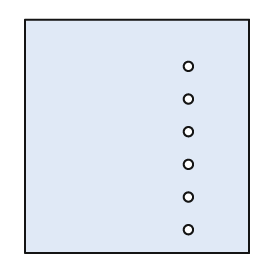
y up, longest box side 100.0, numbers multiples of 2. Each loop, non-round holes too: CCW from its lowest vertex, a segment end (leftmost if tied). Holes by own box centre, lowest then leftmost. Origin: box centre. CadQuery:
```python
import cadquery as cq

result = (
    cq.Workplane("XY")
    .moveTo(-48.0, -50.0)
    .lineTo(48.0, -50.0)
    .lineTo(48.0, 50.0)
    .lineTo(-48.0, 50.0)
    .close()
    .moveTo(22.0, -40.0)
    .circle(2.0)
    .moveTo(22.0, -26.0)
    .circle(2.0)
    .moveTo(22.0, -12.0)
    .circle(2.0)
    .moveTo(22.0, 2.0)
    .circle(2.0)
    .moveTo(22.0, 16.0)
    .circle(2.0)
    .moveTo(22.0, 30.0)
    .circle(2.0)
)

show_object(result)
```